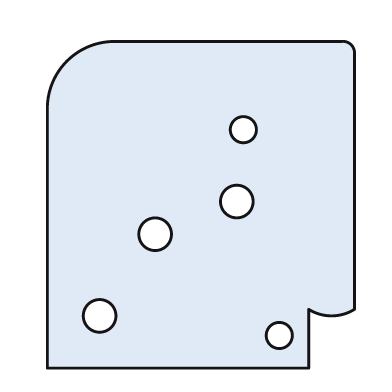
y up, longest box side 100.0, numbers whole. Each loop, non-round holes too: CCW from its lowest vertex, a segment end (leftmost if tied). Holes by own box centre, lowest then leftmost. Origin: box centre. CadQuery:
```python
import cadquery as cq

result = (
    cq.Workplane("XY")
    .moveTo(-47.0, -50.0)
    .lineTo(33.0, -50.0)
    .lineTo(33.0, -32.0)
    .threePointArc((40.0, -34.0), (47.0, -32.0))
    .lineTo(47.0, 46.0)
    .threePointArc((46.0, 49.0), (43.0, 50.0))
    .lineTo(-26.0, 50.0)
    .threePointArc((-41.0, 44.0), (-47.0, 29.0))
    .close()
    .moveTo(24.0, -40.0)
    .circle(4.0)
    .moveTo(-31.0, -34.0)
    .circle(5.0)
    .moveTo(-14.0, -9.0)
    .circle(5.0)
    .moveTo(11.0, 1.0)
    .circle(5.0)
    .moveTo(13.0, 23.0)
    .circle(4.0)
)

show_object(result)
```